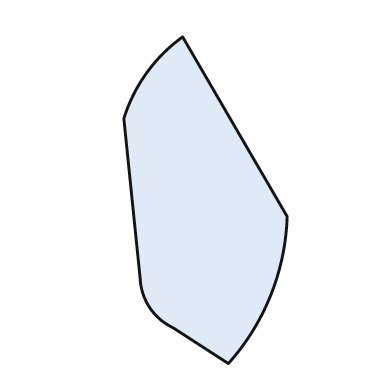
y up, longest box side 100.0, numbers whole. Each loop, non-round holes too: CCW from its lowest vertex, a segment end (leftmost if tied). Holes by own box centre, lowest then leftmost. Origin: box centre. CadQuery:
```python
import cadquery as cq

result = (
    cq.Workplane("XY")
    .moveTo(7.0, -50.0)
    .threePointArc((20.0, -29.0), (25.0, -5.0))
    .lineTo(-7.0, 50.0)
    .threePointArc((-18.0, 39.0), (-25.0, 25.0))
    .lineTo(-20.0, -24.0)
    .threePointArc((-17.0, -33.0), (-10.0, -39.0))
    .close()
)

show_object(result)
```